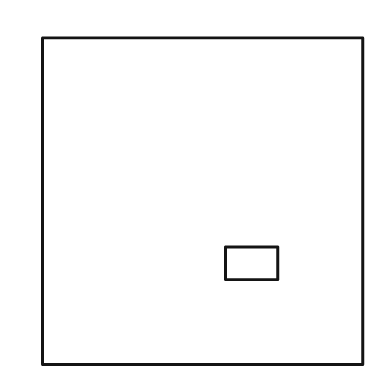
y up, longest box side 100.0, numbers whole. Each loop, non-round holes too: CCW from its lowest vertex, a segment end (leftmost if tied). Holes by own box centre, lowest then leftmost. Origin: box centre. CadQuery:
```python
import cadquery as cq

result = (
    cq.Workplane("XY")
    .moveTo(-49.0, -50.0)
    .lineTo(49.0, -50.0)
    .lineTo(49.0, 50.0)
    .lineTo(-49.0, 50.0)
    .close()
    .moveTo(7.0, -24.0)
    .lineTo(23.0, -24.0)
    .lineTo(23.0, -14.0)
    .lineTo(7.0, -14.0)
    .close()
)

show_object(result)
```